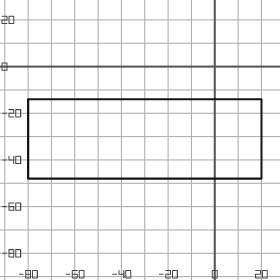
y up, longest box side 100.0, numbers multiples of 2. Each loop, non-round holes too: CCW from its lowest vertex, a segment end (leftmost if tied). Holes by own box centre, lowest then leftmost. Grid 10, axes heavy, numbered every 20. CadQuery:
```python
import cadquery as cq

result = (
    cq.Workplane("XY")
    .moveTo(-80.0, -48.0)
    .lineTo(20.0, -48.0)
    .lineTo(20.0, -14.0)
    .lineTo(-80.0, -14.0)
    .close()
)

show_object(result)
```